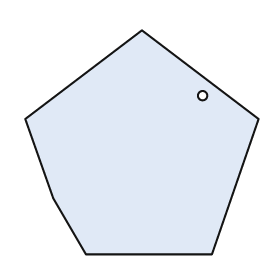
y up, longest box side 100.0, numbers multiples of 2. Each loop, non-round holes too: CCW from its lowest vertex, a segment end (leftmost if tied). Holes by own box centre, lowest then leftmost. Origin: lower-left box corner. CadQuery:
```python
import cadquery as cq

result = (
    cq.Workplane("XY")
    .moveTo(26.0, 0.0)
    .lineTo(80.0, 0.0)
    .lineTo(100.0, 58.0)
    .lineTo(50.0, 96.0)
    .lineTo(0.0, 58.0)
    .lineTo(12.0, 24.0)
    .close()
    .moveTo(76.0, 68.0)
    .circle(2.0)
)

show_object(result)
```